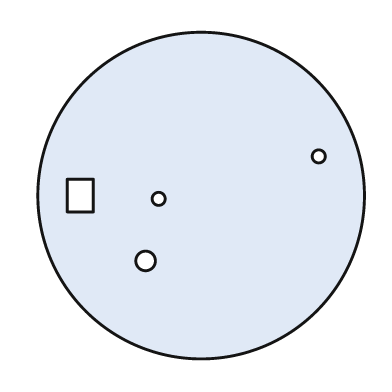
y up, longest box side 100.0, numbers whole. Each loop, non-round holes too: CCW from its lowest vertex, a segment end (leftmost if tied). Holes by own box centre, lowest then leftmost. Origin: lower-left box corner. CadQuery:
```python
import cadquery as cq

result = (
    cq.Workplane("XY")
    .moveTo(50.0, 50.0)
    .circle(50.0)
    .moveTo(33.0, 30.0)
    .circle(3.0)
    .moveTo(37.0, 49.0)
    .circle(2.0)
    .moveTo(9.0, 45.0)
    .lineTo(17.0, 45.0)
    .lineTo(17.0, 55.0)
    .lineTo(9.0, 55.0)
    .close()
    .moveTo(86.0, 62.0)
    .circle(2.0)
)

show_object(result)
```